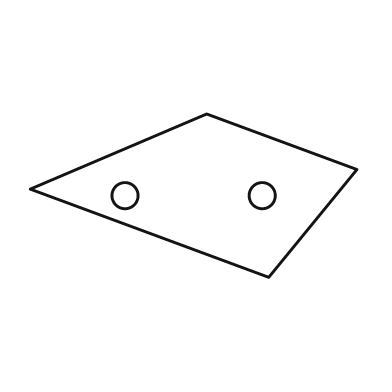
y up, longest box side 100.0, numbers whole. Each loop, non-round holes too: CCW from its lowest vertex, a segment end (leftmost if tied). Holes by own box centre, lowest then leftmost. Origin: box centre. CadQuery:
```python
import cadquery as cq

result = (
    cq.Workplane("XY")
    .moveTo(23.0, -25.0)
    .lineTo(50.0, 8.0)
    .lineTo(4.0, 25.0)
    .lineTo(-50.0, 2.0)
    .close()
    .moveTo(-21.0, 0.0)
    .circle(4.0)
    .moveTo(21.0, 0.0)
    .circle(4.0)
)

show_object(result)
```